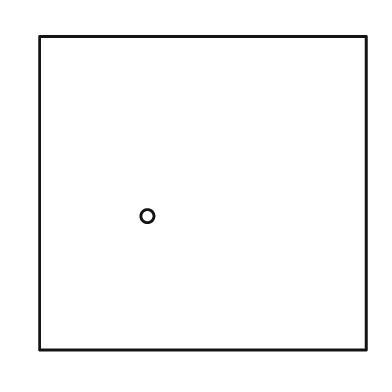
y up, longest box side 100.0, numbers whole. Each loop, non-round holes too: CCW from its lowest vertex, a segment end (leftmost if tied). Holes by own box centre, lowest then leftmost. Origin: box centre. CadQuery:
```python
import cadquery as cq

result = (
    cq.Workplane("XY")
    .moveTo(-50.0, -48.0)
    .lineTo(50.0, -48.0)
    .lineTo(50.0, 48.0)
    .lineTo(-50.0, 48.0)
    .close()
    .moveTo(-17.0, -7.0)
    .circle(2.0)
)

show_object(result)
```